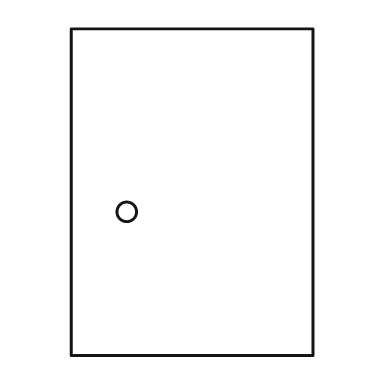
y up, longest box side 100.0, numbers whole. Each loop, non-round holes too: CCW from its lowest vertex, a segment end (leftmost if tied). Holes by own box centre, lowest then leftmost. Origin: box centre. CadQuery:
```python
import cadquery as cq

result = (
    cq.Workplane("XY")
    .moveTo(-37.0, -50.0)
    .lineTo(37.0, -50.0)
    .lineTo(37.0, 50.0)
    .lineTo(-37.0, 50.0)
    .close()
    .moveTo(-20.0, -6.0)
    .circle(3.0)
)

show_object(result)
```